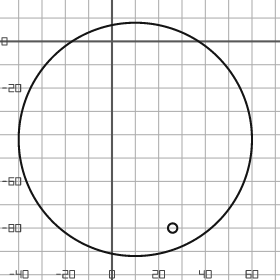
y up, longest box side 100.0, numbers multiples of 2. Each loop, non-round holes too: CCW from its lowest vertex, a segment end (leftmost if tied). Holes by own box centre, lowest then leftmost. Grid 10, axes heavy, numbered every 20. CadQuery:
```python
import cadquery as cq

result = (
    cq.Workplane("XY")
    .moveTo(10.0, -42.0)
    .circle(50.0)
    .moveTo(26.0, -80.0)
    .circle(2.0)
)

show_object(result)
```